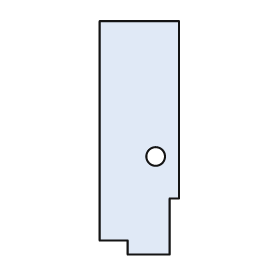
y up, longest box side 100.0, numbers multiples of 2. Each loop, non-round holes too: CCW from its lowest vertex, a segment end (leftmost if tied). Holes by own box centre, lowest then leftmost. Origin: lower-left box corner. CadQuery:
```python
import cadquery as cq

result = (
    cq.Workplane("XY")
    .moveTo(12.0, 0.0)
    .lineTo(30.0, 0.0)
    .lineTo(30.0, 24.0)
    .lineTo(34.0, 24.0)
    .lineTo(34.0, 100.0)
    .lineTo(0.0, 100.0)
    .lineTo(0.0, 6.0)
    .lineTo(12.0, 6.0)
    .close()
    .moveTo(24.0, 42.0)
    .circle(4.0)
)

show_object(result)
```